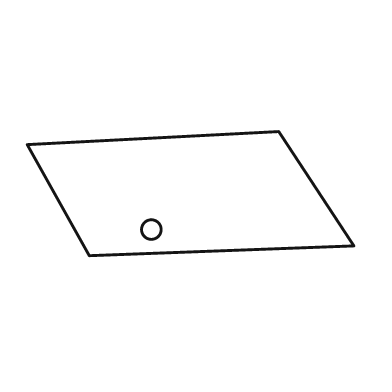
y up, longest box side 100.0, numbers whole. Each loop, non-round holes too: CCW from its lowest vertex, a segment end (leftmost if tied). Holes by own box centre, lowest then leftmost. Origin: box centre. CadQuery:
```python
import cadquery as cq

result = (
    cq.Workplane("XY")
    .moveTo(-31.0, -19.0)
    .lineTo(50.0, -16.0)
    .lineTo(27.0, 19.0)
    .lineTo(-50.0, 15.0)
    .close()
    .moveTo(-12.0, -11.0)
    .circle(3.0)
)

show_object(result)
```